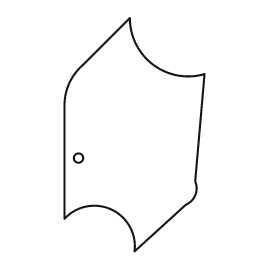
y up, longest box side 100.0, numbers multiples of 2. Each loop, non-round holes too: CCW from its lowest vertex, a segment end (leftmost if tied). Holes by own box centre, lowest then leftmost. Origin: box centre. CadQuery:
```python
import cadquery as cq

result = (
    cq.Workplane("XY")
    .moveTo(0.0, -50.0)
    .lineTo(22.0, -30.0)
    .threePointArc((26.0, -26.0), (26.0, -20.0))
    .lineTo(30.0, 26.0)
    .threePointArc((8.0, 30.0), (-2.0, 50.0))
    .lineTo(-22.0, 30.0)
    .threePointArc((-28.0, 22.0), (-30.0, 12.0))
    .lineTo(-30.0, -36.0)
    .threePointArc((-10.0, -32.0), (0.0, -50.0))
    .close()
    .moveTo(-24.0, -10.0)
    .circle(2.0)
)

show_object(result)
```